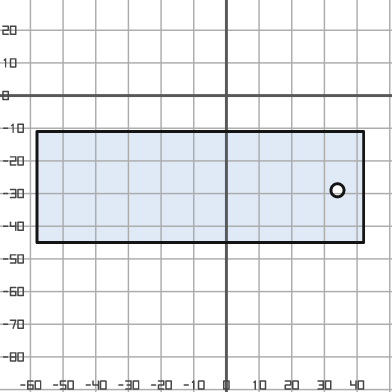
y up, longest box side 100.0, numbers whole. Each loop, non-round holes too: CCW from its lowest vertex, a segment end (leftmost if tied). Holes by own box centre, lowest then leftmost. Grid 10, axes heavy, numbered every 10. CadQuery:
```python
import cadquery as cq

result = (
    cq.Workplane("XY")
    .moveTo(-58.0, -45.0)
    .lineTo(42.0, -45.0)
    .lineTo(42.0, -11.0)
    .lineTo(-58.0, -11.0)
    .close()
    .moveTo(34.0, -29.0)
    .circle(2.0)
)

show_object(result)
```